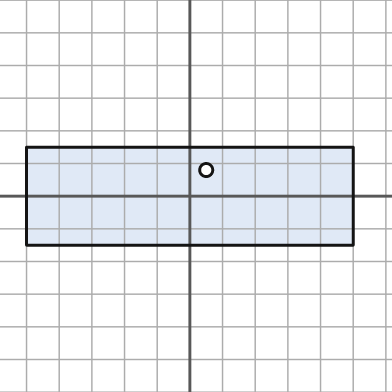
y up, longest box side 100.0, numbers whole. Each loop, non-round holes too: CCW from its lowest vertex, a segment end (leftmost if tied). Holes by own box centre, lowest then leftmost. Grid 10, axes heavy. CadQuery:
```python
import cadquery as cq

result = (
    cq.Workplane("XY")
    .moveTo(-50.0, -15.0)
    .lineTo(50.0, -15.0)
    .lineTo(50.0, 15.0)
    .lineTo(-50.0, 15.0)
    .close()
    .moveTo(5.0, 8.0)
    .circle(2.0)
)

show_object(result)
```